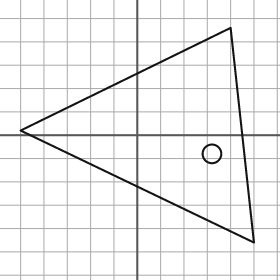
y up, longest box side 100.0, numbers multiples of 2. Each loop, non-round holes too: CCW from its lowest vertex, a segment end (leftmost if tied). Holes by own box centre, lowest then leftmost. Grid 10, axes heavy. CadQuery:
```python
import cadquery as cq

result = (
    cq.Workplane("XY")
    .moveTo(50.0, -46.0)
    .lineTo(40.0, 46.0)
    .lineTo(-50.0, 2.0)
    .close()
    .moveTo(32.0, -8.0)
    .circle(4.0)
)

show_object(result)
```